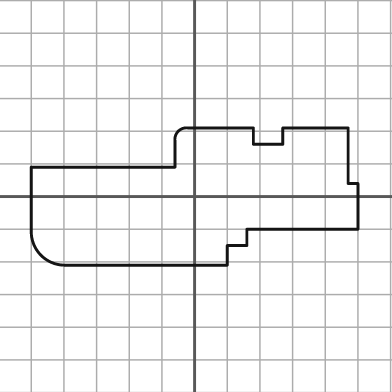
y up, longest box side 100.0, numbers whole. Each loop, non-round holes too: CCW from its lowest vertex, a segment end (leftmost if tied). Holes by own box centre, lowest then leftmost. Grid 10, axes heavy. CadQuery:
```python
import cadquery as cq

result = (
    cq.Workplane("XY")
    .moveTo(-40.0, -21.0)
    .lineTo(10.0, -21.0)
    .lineTo(10.0, -15.0)
    .lineTo(16.0, -15.0)
    .lineTo(16.0, -10.0)
    .lineTo(50.0, -10.0)
    .lineTo(50.0, 4.0)
    .lineTo(47.0, 4.0)
    .lineTo(47.0, 21.0)
    .lineTo(27.0, 21.0)
    .lineTo(27.0, 16.0)
    .lineTo(18.0, 16.0)
    .lineTo(18.0, 21.0)
    .lineTo(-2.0, 21.0)
    .threePointArc((-5.0, 20.0), (-6.0, 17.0))
    .lineTo(-6.0, 9.0)
    .lineTo(-50.0, 9.0)
    .lineTo(-50.0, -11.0)
    .threePointArc((-47.0, -18.0), (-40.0, -21.0))
    .close()
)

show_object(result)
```